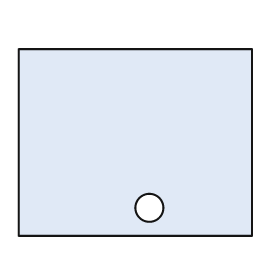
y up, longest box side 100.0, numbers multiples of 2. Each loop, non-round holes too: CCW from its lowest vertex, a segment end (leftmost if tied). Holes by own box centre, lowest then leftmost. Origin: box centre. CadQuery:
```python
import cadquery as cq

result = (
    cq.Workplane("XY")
    .moveTo(-50.0, -40.0)
    .lineTo(50.0, -40.0)
    .lineTo(50.0, 40.0)
    .lineTo(-50.0, 40.0)
    .close()
    .moveTo(6.0, -28.0)
    .circle(6.0)
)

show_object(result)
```